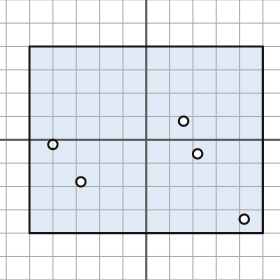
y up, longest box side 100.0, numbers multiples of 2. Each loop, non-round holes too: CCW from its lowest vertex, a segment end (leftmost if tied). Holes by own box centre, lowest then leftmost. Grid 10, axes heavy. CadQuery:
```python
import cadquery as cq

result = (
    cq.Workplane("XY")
    .moveTo(-50.0, -40.0)
    .lineTo(50.0, -40.0)
    .lineTo(50.0, 40.0)
    .lineTo(-50.0, 40.0)
    .close()
    .moveTo(42.0, -34.0)
    .circle(2.0)
    .moveTo(-28.0, -18.0)
    .circle(2.0)
    .moveTo(22.0, -6.0)
    .circle(2.0)
    .moveTo(-40.0, -2.0)
    .circle(2.0)
    .moveTo(16.0, 8.0)
    .circle(2.0)
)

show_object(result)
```